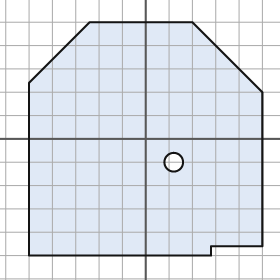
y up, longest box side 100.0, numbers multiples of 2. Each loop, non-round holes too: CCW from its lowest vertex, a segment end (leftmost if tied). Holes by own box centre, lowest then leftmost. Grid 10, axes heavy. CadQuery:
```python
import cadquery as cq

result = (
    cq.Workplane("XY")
    .moveTo(-50.0, -50.0)
    .lineTo(28.0, -50.0)
    .lineTo(28.0, -46.0)
    .lineTo(50.0, -46.0)
    .lineTo(50.0, 20.0)
    .lineTo(20.0, 50.0)
    .lineTo(-24.0, 50.0)
    .lineTo(-50.0, 24.0)
    .close()
    .moveTo(12.0, -10.0)
    .circle(4.0)
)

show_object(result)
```